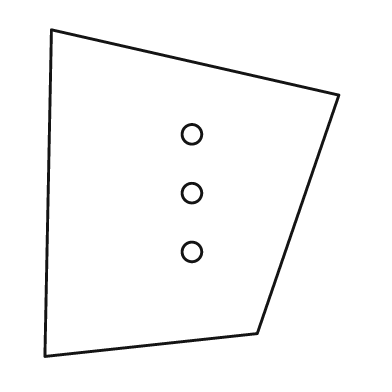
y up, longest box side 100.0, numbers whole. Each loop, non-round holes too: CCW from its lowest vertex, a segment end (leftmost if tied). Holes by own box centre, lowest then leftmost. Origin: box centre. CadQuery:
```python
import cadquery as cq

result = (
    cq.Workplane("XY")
    .moveTo(-45.0, -50.0)
    .lineTo(20.0, -43.0)
    .lineTo(45.0, 30.0)
    .lineTo(-43.0, 50.0)
    .close()
    .moveTo(0.0, -18.0)
    .circle(3.0)
    .moveTo(0.0, 0.0)
    .circle(3.0)
    .moveTo(0.0, 18.0)
    .circle(3.0)
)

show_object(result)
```